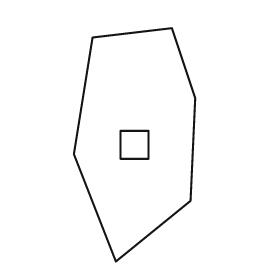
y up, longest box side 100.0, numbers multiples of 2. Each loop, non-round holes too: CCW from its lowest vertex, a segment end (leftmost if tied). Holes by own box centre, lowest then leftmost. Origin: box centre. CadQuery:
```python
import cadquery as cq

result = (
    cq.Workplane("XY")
    .moveTo(-8.0, -50.0)
    .lineTo(24.0, -24.0)
    .lineTo(26.0, 20.0)
    .lineTo(16.0, 50.0)
    .lineTo(-18.0, 46.0)
    .lineTo(-26.0, -4.0)
    .close()
    .moveTo(-6.0, -6.0)
    .lineTo(6.0, -6.0)
    .lineTo(6.0, 6.0)
    .lineTo(-6.0, 6.0)
    .close()
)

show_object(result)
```